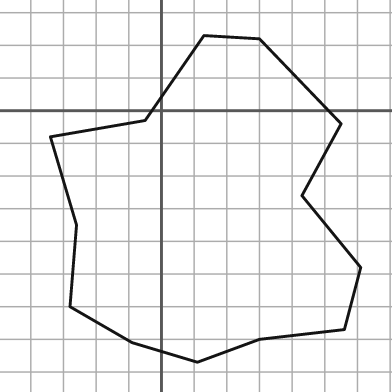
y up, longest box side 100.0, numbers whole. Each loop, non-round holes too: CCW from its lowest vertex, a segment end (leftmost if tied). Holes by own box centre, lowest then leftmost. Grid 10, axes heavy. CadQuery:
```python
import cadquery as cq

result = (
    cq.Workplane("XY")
    .moveTo(11.0, -77.0)
    .lineTo(30.0, -70.0)
    .lineTo(56.0, -67.0)
    .lineTo(61.0, -48.0)
    .lineTo(43.0, -26.0)
    .lineTo(55.0, -4.0)
    .lineTo(30.0, 22.0)
    .lineTo(13.0, 23.0)
    .lineTo(-5.0, -3.0)
    .lineTo(-34.0, -8.0)
    .lineTo(-26.0, -35.0)
    .lineTo(-28.0, -60.0)
    .lineTo(-9.0, -71.0)
    .close()
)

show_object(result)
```